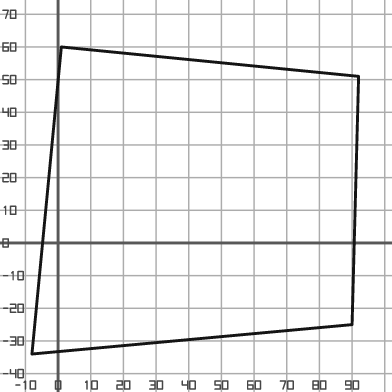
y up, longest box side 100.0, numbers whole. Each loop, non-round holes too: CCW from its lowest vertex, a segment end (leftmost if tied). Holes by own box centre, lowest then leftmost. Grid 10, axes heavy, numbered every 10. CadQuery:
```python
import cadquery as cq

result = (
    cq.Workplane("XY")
    .moveTo(-8.0, -34.0)
    .lineTo(90.0, -25.0)
    .lineTo(92.0, 51.0)
    .lineTo(1.0, 60.0)
    .close()
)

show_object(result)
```